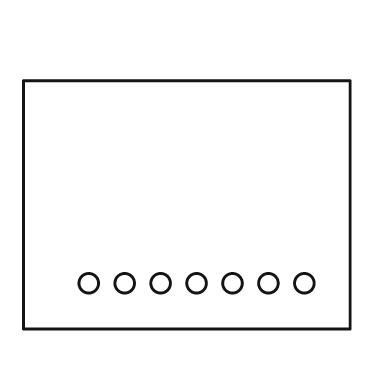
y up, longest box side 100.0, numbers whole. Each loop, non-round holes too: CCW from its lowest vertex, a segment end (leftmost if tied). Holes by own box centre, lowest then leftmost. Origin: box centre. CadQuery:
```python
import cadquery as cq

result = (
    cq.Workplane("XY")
    .moveTo(-50.0, -38.0)
    .lineTo(50.0, -38.0)
    .lineTo(50.0, 38.0)
    .lineTo(-50.0, 38.0)
    .close()
    .moveTo(-30.0, -24.0)
    .circle(3.0)
    .moveTo(-19.0, -24.0)
    .circle(3.0)
    .moveTo(-8.0, -24.0)
    .circle(3.0)
    .moveTo(3.0, -24.0)
    .circle(3.0)
    .moveTo(14.0, -24.0)
    .circle(3.0)
    .moveTo(25.0, -24.0)
    .circle(3.0)
    .moveTo(36.0, -24.0)
    .circle(3.0)
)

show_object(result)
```